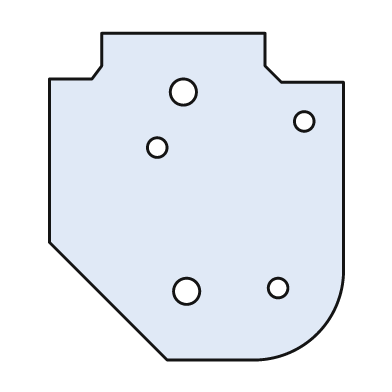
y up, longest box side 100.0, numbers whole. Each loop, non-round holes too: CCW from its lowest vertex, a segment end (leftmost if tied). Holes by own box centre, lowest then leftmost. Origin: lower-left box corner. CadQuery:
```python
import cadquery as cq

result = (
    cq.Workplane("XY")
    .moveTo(36.0, 0.0)
    .lineTo(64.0, 0.0)
    .threePointArc((82.0, 8.0), (90.0, 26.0))
    .lineTo(90.0, 85.0)
    .lineTo(71.0, 85.0)
    .lineTo(66.0, 90.0)
    .lineTo(66.0, 100.0)
    .lineTo(16.0, 100.0)
    .lineTo(16.0, 90.0)
    .lineTo(13.0, 86.0)
    .lineTo(0.0, 86.0)
    .lineTo(0.0, 36.0)
    .close()
    .moveTo(42.0, 21.0)
    .circle(4.0)
    .moveTo(70.0, 22.0)
    .circle(3.0)
    .moveTo(33.0, 65.0)
    .circle(3.0)
    .moveTo(78.0, 73.0)
    .circle(3.0)
    .moveTo(41.0, 82.0)
    .circle(4.0)
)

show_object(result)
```